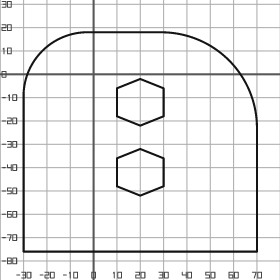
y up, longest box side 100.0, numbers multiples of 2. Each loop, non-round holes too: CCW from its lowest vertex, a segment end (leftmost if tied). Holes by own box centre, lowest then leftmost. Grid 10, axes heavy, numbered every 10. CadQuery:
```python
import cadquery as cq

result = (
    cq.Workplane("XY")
    .moveTo(-30.0, -76.0)
    .lineTo(70.0, -76.0)
    .lineTo(70.0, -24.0)
    .threePointArc((58.0, 6.0), (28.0, 18.0))
    .lineTo(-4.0, 18.0)
    .threePointArc((-22.0, 10.0), (-30.0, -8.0))
    .close()
    .moveTo(20.0, -52.0)
    .lineTo(30.0, -48.0)
    .lineTo(30.0, -36.0)
    .lineTo(20.0, -32.0)
    .lineTo(10.0, -36.0)
    .lineTo(10.0, -48.0)
    .close()
    .moveTo(20.0, -22.0)
    .lineTo(30.0, -18.0)
    .lineTo(30.0, -6.0)
    .lineTo(20.0, -2.0)
    .lineTo(10.0, -6.0)
    .lineTo(10.0, -18.0)
    .close()
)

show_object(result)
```